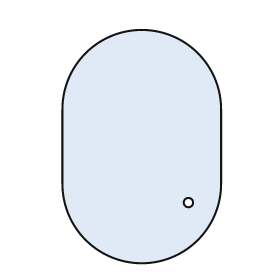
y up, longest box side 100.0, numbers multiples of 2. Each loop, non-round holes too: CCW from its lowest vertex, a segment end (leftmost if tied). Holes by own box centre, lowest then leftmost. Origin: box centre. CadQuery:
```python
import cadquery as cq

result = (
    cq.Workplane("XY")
    .moveTo(-34.0, -16.0)
    .threePointArc((0.0, -50.0), (34.0, -16.0))
    .lineTo(34.0, 16.0)
    .threePointArc((0.0, 50.0), (-34.0, 16.0))
    .close()
    .moveTo(20.0, -24.0)
    .circle(2.0)
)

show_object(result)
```